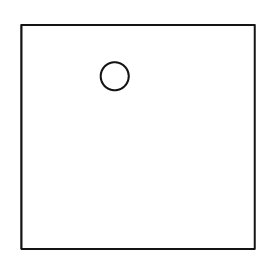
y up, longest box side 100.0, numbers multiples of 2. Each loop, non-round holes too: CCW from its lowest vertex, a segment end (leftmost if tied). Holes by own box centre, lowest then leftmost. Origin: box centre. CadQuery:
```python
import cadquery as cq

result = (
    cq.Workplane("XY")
    .moveTo(-50.0, -48.0)
    .lineTo(50.0, -48.0)
    .lineTo(50.0, 48.0)
    .lineTo(-50.0, 48.0)
    .close()
    .moveTo(-10.0, 26.0)
    .circle(6.0)
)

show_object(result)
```